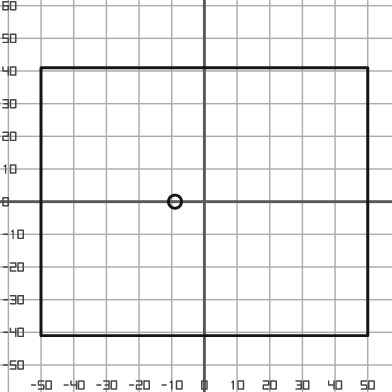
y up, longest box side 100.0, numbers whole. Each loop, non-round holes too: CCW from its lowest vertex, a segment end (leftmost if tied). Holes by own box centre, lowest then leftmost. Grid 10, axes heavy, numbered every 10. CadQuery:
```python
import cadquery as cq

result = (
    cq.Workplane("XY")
    .moveTo(-50.0, -41.0)
    .lineTo(50.0, -41.0)
    .lineTo(50.0, 41.0)
    .lineTo(-50.0, 41.0)
    .close()
    .moveTo(-9.0, 0.0)
    .circle(2.0)
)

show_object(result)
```